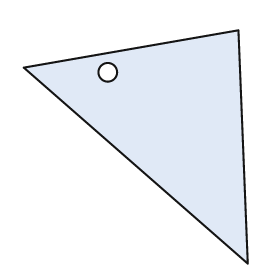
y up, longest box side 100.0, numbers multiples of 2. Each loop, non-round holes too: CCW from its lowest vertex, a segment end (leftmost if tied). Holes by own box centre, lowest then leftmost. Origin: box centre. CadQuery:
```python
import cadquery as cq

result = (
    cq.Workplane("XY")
    .moveTo(48.0, -50.0)
    .lineTo(44.0, 50.0)
    .lineTo(-48.0, 34.0)
    .close()
    .moveTo(-12.0, 32.0)
    .circle(4.0)
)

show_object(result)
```